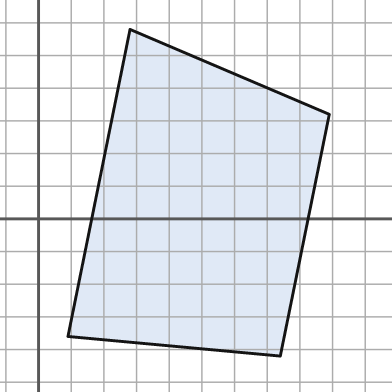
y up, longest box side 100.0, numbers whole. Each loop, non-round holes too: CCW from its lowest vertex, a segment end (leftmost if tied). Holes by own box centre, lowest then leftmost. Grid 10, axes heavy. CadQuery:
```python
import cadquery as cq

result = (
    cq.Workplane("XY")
    .moveTo(74.0, -42.0)
    .lineTo(89.0, 32.0)
    .lineTo(28.0, 58.0)
    .lineTo(9.0, -36.0)
    .close()
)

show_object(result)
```